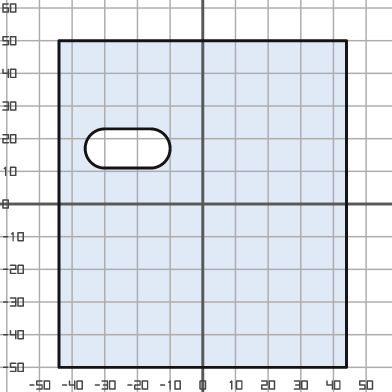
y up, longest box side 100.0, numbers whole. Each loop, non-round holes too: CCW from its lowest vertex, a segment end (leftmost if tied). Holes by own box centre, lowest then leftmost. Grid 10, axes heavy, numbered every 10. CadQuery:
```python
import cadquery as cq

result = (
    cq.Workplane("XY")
    .moveTo(-44.0, -50.0)
    .lineTo(44.0, -50.0)
    .lineTo(44.0, 50.0)
    .lineTo(-44.0, 50.0)
    .close()
    .moveTo(-30.0, 11.0)
    .lineTo(-16.0, 11.0)
    .threePointArc((-10.0, 17.0), (-16.0, 23.0))
    .lineTo(-30.0, 23.0)
    .threePointArc((-36.0, 17.0), (-30.0, 11.0))
    .close()
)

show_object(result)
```